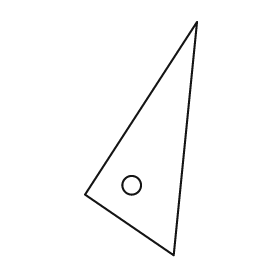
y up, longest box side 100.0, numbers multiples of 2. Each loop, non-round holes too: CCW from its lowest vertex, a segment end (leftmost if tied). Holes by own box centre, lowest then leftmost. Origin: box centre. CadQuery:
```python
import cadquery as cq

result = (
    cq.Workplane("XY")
    .moveTo(14.0, -50.0)
    .lineTo(24.0, 50.0)
    .lineTo(-24.0, -24.0)
    .close()
    .moveTo(-4.0, -20.0)
    .circle(4.0)
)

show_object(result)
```